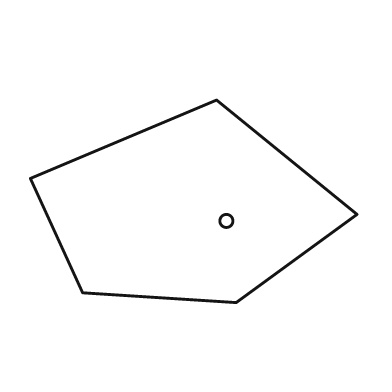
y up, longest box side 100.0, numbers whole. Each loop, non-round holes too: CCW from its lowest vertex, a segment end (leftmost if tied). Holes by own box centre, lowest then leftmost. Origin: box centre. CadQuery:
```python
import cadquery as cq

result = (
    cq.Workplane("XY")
    .moveTo(13.0, -31.0)
    .lineTo(50.0, -4.0)
    .lineTo(7.0, 31.0)
    .lineTo(-50.0, 7.0)
    .lineTo(-34.0, -28.0)
    .close()
    .moveTo(10.0, -6.0)
    .circle(2.0)
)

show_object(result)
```